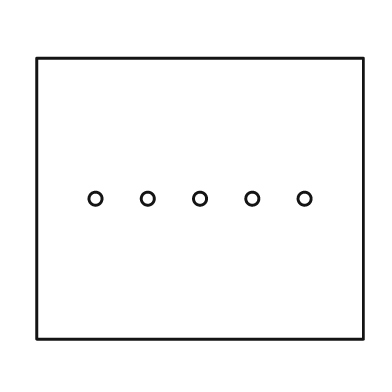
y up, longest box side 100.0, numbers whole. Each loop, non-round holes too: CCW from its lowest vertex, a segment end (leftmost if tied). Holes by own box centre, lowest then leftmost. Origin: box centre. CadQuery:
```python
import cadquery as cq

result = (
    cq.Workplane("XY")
    .moveTo(-50.0, -43.0)
    .lineTo(50.0, -43.0)
    .lineTo(50.0, 43.0)
    .lineTo(-50.0, 43.0)
    .close()
    .moveTo(-32.0, 0.0)
    .circle(2.0)
    .moveTo(-16.0, 0.0)
    .circle(2.0)
    .moveTo(0.0, 0.0)
    .circle(2.0)
    .moveTo(16.0, 0.0)
    .circle(2.0)
    .moveTo(32.0, 0.0)
    .circle(2.0)
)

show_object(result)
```